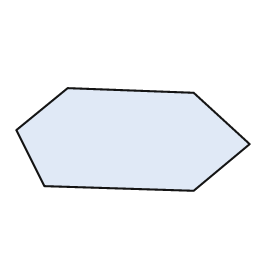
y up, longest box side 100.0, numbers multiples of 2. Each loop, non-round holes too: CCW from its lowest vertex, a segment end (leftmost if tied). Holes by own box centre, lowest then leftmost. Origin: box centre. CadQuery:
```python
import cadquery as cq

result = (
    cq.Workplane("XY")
    .moveTo(26.0, -22.0)
    .lineTo(50.0, -2.0)
    .lineTo(26.0, 20.0)
    .lineTo(-28.0, 22.0)
    .lineTo(-50.0, 4.0)
    .lineTo(-38.0, -20.0)
    .close()
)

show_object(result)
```